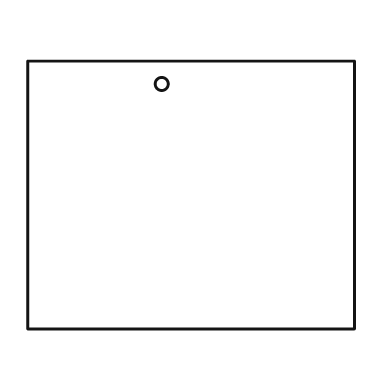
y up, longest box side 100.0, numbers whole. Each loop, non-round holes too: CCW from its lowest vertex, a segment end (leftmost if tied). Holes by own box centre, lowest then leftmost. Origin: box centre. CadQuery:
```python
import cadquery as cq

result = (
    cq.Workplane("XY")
    .moveTo(-50.0, -41.0)
    .lineTo(50.0, -41.0)
    .lineTo(50.0, 41.0)
    .lineTo(-50.0, 41.0)
    .close()
    .moveTo(-9.0, 34.0)
    .circle(2.0)
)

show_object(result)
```